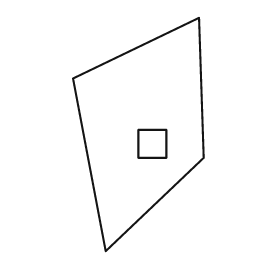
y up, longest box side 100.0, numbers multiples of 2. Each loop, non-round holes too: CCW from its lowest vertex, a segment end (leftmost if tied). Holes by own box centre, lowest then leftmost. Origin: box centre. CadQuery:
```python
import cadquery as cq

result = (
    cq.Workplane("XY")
    .moveTo(-14.0, -50.0)
    .lineTo(28.0, -10.0)
    .lineTo(26.0, 50.0)
    .lineTo(-28.0, 24.0)
    .close()
    .moveTo(0.0, -10.0)
    .lineTo(12.0, -10.0)
    .lineTo(12.0, 2.0)
    .lineTo(0.0, 2.0)
    .close()
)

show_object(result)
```